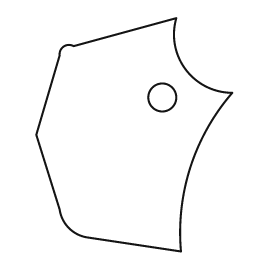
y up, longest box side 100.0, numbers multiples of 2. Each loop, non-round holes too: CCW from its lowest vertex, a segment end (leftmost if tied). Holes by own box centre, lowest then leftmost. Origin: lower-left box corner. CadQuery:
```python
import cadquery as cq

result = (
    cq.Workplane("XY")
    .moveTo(62.0, 0.0)
    .threePointArc((66.0, 36.0), (84.0, 68.0))
    .threePointArc((64.0, 78.0), (60.0, 100.0))
    .lineTo(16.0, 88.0)
    .threePointArc((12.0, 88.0), (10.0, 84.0))
    .lineTo(0.0, 50.0)
    .lineTo(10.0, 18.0)
    .threePointArc((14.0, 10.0), (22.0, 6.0))
    .close()
    .moveTo(54.0, 66.0)
    .circle(6.0)
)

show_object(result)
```